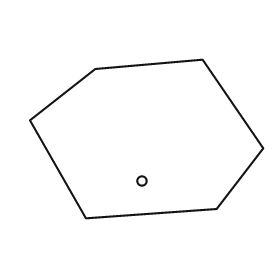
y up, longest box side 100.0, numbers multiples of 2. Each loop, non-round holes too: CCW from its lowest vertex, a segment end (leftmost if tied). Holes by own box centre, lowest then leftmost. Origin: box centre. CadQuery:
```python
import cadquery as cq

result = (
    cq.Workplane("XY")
    .moveTo(-26.0, -34.0)
    .lineTo(30.0, -30.0)
    .lineTo(50.0, -4.0)
    .lineTo(24.0, 34.0)
    .lineTo(-22.0, 30.0)
    .lineTo(-50.0, 8.0)
    .close()
    .moveTo(-2.0, -18.0)
    .circle(2.0)
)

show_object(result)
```